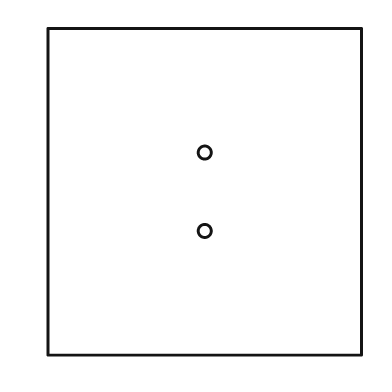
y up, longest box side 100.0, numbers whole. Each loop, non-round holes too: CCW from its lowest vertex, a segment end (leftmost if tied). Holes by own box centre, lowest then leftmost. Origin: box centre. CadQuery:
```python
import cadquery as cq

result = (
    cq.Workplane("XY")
    .moveTo(-48.0, -50.0)
    .lineTo(48.0, -50.0)
    .lineTo(48.0, 50.0)
    .lineTo(-48.0, 50.0)
    .close()
    .moveTo(0.0, -12.0)
    .circle(2.0)
    .moveTo(0.0, 12.0)
    .circle(2.0)
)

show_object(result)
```